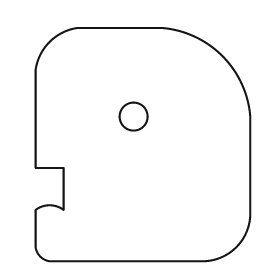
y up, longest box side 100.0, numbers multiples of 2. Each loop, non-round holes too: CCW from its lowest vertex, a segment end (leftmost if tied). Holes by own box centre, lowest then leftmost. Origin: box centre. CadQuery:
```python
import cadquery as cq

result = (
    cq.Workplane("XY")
    .moveTo(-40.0, -50.0)
    .lineTo(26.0, -50.0)
    .threePointArc((40.0, -44.0), (46.0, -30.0))
    .lineTo(46.0, 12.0)
    .threePointArc((34.0, 38.0), (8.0, 50.0))
    .lineTo(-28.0, 50.0)
    .threePointArc((-40.0, 44.0), (-46.0, 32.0))
    .lineTo(-46.0, -10.0)
    .lineTo(-34.0, -10.0)
    .lineTo(-34.0, -28.0)
    .threePointArc((-40.0, -26.0), (-46.0, -28.0))
    .lineTo(-46.0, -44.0)
    .threePointArc((-44.0, -48.0), (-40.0, -50.0))
    .close()
    .moveTo(-4.0, 12.0)
    .circle(6.0)
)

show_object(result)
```